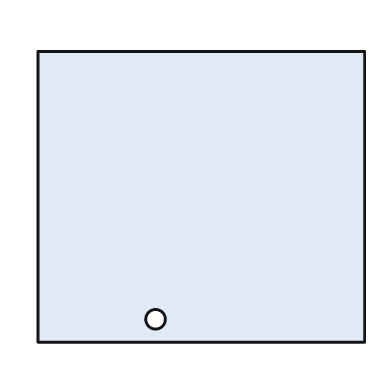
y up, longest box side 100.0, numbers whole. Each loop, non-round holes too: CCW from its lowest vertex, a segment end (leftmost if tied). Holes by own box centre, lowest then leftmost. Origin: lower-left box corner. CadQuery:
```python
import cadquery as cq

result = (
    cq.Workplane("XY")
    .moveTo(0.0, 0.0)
    .lineTo(100.0, 0.0)
    .lineTo(100.0, 89.0)
    .lineTo(0.0, 89.0)
    .close()
    .moveTo(36.0, 7.0)
    .circle(3.0)
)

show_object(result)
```